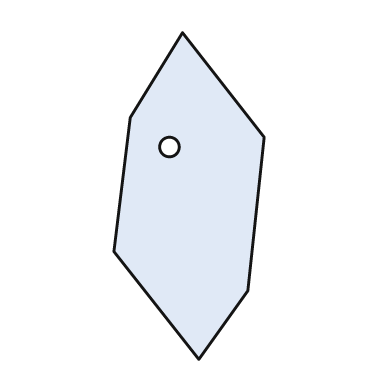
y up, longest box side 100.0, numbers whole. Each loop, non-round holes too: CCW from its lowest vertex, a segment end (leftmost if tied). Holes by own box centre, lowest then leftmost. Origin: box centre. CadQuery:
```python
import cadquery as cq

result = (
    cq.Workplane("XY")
    .moveTo(3.0, -50.0)
    .lineTo(18.0, -29.0)
    .lineTo(23.0, 18.0)
    .lineTo(-2.0, 50.0)
    .lineTo(-18.0, 24.0)
    .lineTo(-23.0, -17.0)
    .close()
    .moveTo(-6.0, 15.0)
    .circle(3.0)
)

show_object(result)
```